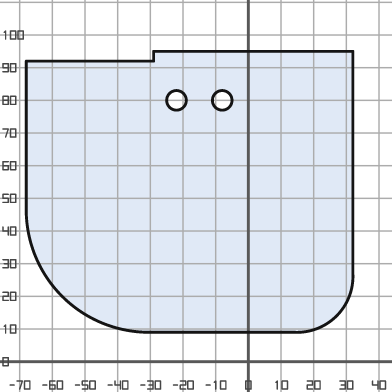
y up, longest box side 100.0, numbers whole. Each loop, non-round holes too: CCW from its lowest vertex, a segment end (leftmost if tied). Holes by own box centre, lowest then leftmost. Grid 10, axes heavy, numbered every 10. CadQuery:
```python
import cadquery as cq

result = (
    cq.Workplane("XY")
    .moveTo(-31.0, 9.0)
    .lineTo(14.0, 9.0)
    .threePointArc((27.0, 14.0), (32.0, 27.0))
    .lineTo(32.0, 95.0)
    .lineTo(-29.0, 95.0)
    .lineTo(-29.0, 92.0)
    .lineTo(-68.0, 92.0)
    .lineTo(-68.0, 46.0)
    .threePointArc((-57.0, 20.0), (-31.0, 9.0))
    .close()
    .moveTo(-22.0, 80.0)
    .circle(3.0)
    .moveTo(-8.0, 80.0)
    .circle(3.0)
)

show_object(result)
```